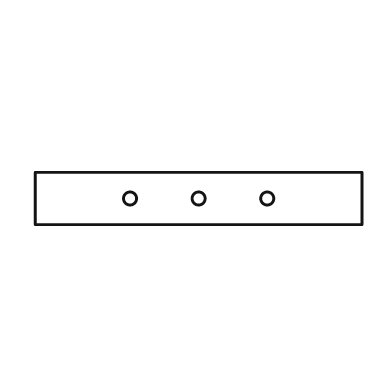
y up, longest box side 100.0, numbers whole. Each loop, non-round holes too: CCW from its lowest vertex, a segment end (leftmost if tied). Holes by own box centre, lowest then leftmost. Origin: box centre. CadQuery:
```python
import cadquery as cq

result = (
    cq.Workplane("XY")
    .moveTo(-50.0, -8.0)
    .lineTo(50.0, -8.0)
    .lineTo(50.0, 8.0)
    .lineTo(-50.0, 8.0)
    .close()
    .moveTo(-21.0, 0.0)
    .circle(2.0)
    .moveTo(0.0, 0.0)
    .circle(2.0)
    .moveTo(21.0, 0.0)
    .circle(2.0)
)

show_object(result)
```